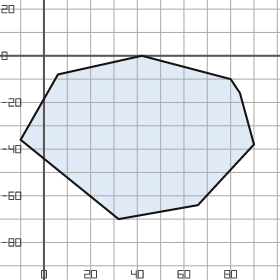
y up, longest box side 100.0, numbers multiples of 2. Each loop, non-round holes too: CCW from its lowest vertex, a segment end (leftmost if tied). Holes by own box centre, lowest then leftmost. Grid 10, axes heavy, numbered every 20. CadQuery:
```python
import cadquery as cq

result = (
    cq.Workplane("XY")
    .moveTo(32.0, -70.0)
    .lineTo(66.0, -64.0)
    .lineTo(90.0, -38.0)
    .lineTo(84.0, -16.0)
    .lineTo(80.0, -10.0)
    .lineTo(42.0, 0.0)
    .lineTo(6.0, -8.0)
    .lineTo(-10.0, -36.0)
    .close()
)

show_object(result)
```